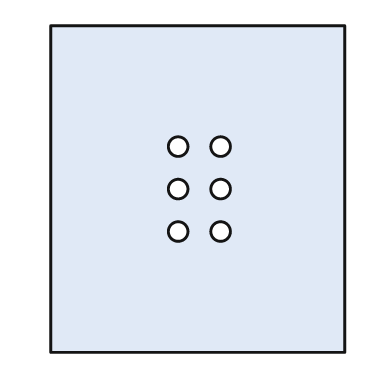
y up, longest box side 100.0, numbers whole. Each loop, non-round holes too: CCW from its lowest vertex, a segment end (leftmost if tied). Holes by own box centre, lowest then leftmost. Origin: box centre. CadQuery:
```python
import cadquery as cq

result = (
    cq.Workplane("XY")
    .moveTo(-45.0, -50.0)
    .lineTo(45.0, -50.0)
    .lineTo(45.0, 50.0)
    .lineTo(-45.0, 50.0)
    .close()
    .moveTo(-6.0, -13.0)
    .circle(3.0)
    .moveTo(7.0, -13.0)
    .circle(3.0)
    .moveTo(-6.0, 0.0)
    .circle(3.0)
    .moveTo(7.0, 0.0)
    .circle(3.0)
    .moveTo(-6.0, 13.0)
    .circle(3.0)
    .moveTo(7.0, 13.0)
    .circle(3.0)
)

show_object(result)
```